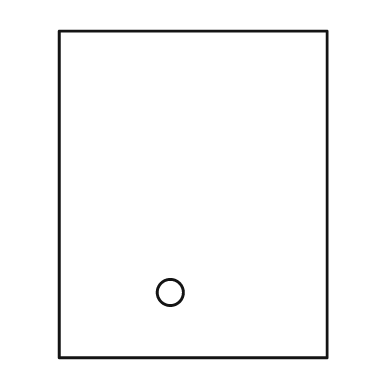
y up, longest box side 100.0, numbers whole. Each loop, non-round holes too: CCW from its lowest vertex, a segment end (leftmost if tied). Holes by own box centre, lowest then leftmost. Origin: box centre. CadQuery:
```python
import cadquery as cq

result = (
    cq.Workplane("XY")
    .moveTo(-41.0, -50.0)
    .lineTo(41.0, -50.0)
    .lineTo(41.0, 50.0)
    .lineTo(-41.0, 50.0)
    .close()
    .moveTo(-7.0, -30.0)
    .circle(4.0)
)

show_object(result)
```